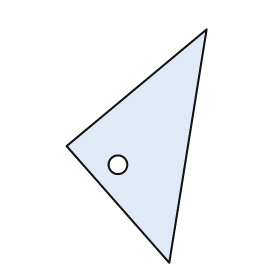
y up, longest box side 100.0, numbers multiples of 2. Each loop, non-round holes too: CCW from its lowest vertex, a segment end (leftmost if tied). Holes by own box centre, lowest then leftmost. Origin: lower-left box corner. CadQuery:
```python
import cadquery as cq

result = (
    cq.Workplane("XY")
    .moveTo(44.0, 0.0)
    .lineTo(60.0, 100.0)
    .lineTo(0.0, 50.0)
    .close()
    .moveTo(22.0, 42.0)
    .circle(4.0)
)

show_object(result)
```